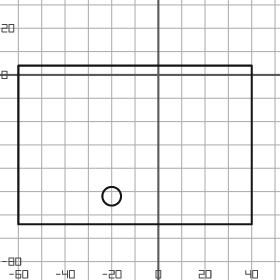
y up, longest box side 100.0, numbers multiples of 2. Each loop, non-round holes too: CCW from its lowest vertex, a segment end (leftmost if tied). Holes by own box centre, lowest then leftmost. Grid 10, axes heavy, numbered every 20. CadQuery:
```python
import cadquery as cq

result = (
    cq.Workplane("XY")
    .moveTo(-60.0, -64.0)
    .lineTo(40.0, -64.0)
    .lineTo(40.0, 4.0)
    .lineTo(-60.0, 4.0)
    .close()
    .moveTo(-20.0, -52.0)
    .circle(4.0)
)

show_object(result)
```